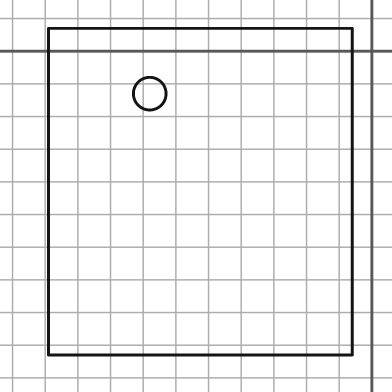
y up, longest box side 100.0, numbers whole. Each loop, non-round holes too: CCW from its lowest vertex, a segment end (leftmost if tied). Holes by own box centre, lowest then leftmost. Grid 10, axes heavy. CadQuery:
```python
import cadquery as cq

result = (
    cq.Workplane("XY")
    .moveTo(-99.0, -93.0)
    .lineTo(-6.0, -93.0)
    .lineTo(-6.0, 7.0)
    .lineTo(-99.0, 7.0)
    .close()
    .moveTo(-68.0, -13.0)
    .circle(5.0)
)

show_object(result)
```